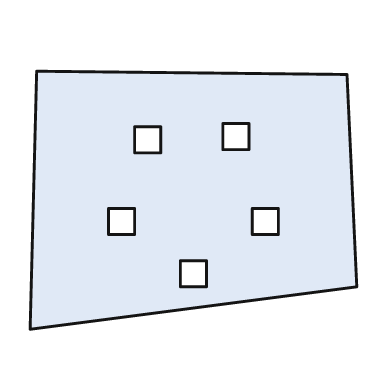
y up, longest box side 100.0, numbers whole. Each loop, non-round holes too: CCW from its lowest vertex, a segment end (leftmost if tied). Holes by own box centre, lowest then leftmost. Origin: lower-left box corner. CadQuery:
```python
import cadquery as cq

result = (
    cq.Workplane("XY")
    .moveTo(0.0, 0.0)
    .lineTo(100.0, 13.0)
    .lineTo(97.0, 78.0)
    .lineTo(2.0, 79.0)
    .close()
    .moveTo(46.0, 13.0)
    .lineTo(54.0, 13.0)
    .lineTo(54.0, 21.0)
    .lineTo(46.0, 21.0)
    .close()
    .moveTo(24.0, 29.0)
    .lineTo(32.0, 29.0)
    .lineTo(32.0, 37.0)
    .lineTo(24.0, 37.0)
    .close()
    .moveTo(68.0, 29.0)
    .lineTo(76.0, 29.0)
    .lineTo(76.0, 37.0)
    .lineTo(68.0, 37.0)
    .close()
    .moveTo(32.0, 54.0)
    .lineTo(40.0, 54.0)
    .lineTo(40.0, 62.0)
    .lineTo(32.0, 62.0)
    .close()
    .moveTo(59.0, 55.0)
    .lineTo(67.0, 55.0)
    .lineTo(67.0, 63.0)
    .lineTo(59.0, 63.0)
    .close()
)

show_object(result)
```